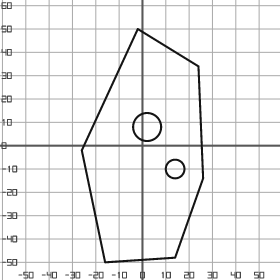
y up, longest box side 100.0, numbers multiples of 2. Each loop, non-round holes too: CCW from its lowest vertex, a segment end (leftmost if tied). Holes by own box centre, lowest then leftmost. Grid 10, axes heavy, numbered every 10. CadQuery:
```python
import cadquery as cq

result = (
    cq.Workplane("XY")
    .moveTo(-16.0, -50.0)
    .lineTo(14.0, -48.0)
    .lineTo(26.0, -14.0)
    .lineTo(24.0, 34.0)
    .lineTo(-2.0, 50.0)
    .lineTo(-26.0, -2.0)
    .close()
    .moveTo(14.0, -10.0)
    .circle(4.0)
    .moveTo(2.0, 8.0)
    .circle(6.0)
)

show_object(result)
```